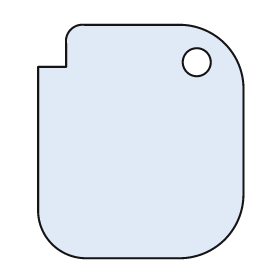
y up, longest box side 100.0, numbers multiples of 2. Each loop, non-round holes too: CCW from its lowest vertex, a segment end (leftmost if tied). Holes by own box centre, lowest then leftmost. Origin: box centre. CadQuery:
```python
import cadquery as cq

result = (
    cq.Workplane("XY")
    .moveTo(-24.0, -50.0)
    .lineTo(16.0, -50.0)
    .threePointArc((36.0, -42.0), (44.0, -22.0))
    .lineTo(44.0, 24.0)
    .threePointArc((36.0, 42.0), (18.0, 50.0))
    .lineTo(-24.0, 50.0)
    .threePointArc((-30.0, 48.0), (-32.0, 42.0))
    .lineTo(-32.0, 32.0)
    .lineTo(-44.0, 32.0)
    .lineTo(-44.0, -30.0)
    .threePointArc((-38.0, -44.0), (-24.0, -50.0))
    .close()
    .moveTo(24.0, 34.0)
    .circle(6.0)
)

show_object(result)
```